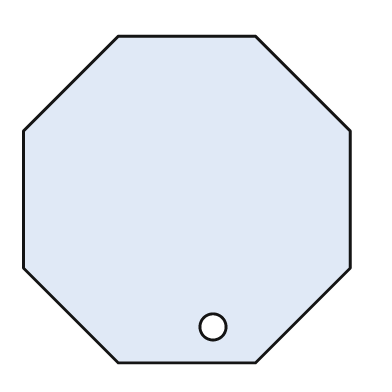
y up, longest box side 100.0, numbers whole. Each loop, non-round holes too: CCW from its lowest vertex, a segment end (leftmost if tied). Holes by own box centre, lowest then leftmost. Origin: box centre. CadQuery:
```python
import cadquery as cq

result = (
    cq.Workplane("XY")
    .moveTo(-21.0, -50.0)
    .lineTo(21.0, -50.0)
    .lineTo(50.0, -21.0)
    .lineTo(50.0, 21.0)
    .lineTo(21.0, 50.0)
    .lineTo(-21.0, 50.0)
    .lineTo(-50.0, 21.0)
    .lineTo(-50.0, -21.0)
    .close()
    .moveTo(8.0, -39.0)
    .circle(4.0)
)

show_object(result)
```